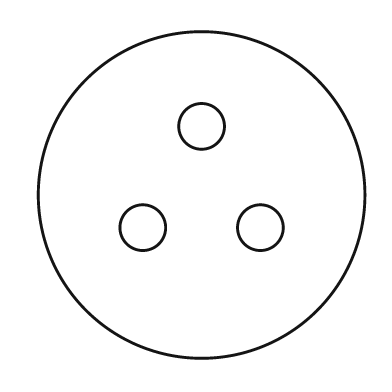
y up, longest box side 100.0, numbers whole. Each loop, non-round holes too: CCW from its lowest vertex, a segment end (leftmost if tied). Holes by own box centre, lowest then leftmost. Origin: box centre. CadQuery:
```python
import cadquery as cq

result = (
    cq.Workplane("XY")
    .moveTo(0.0, 0.0)
    .circle(50.0)
    .moveTo(-18.0, -10.0)
    .circle(7.0)
    .moveTo(18.0, -10.0)
    .circle(7.0)
    .moveTo(0.0, 21.0)
    .circle(7.0)
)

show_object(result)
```